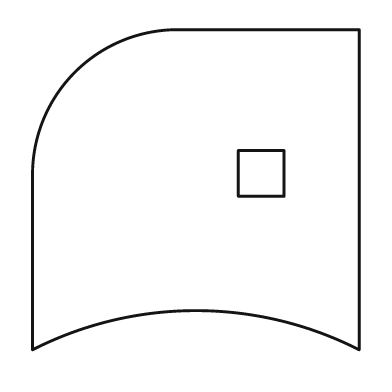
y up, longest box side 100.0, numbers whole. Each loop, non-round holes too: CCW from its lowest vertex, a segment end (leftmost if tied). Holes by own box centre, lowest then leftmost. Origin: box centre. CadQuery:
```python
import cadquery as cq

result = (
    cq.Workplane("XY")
    .moveTo(-50.0, -49.0)
    .threePointArc((0.0, -37.0), (50.0, -49.0))
    .lineTo(50.0, 49.0)
    .lineTo(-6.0, 49.0)
    .threePointArc((-37.0, 36.0), (-50.0, 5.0))
    .close()
    .moveTo(13.0, -2.0)
    .lineTo(27.0, -2.0)
    .lineTo(27.0, 12.0)
    .lineTo(13.0, 12.0)
    .close()
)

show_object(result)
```